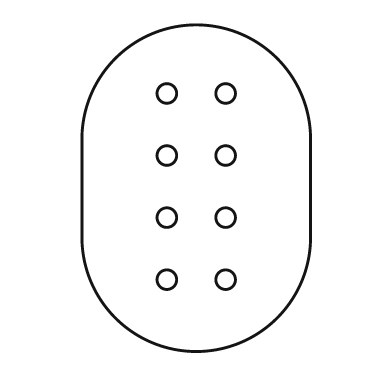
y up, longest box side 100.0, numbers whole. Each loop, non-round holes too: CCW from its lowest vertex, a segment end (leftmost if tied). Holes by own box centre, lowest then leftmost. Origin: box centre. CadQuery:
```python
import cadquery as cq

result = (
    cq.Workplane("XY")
    .moveTo(-35.0, -15.0)
    .threePointArc((0.0, -50.0), (35.0, -15.0))
    .lineTo(35.0, 15.0)
    .threePointArc((0.0, 50.0), (-35.0, 15.0))
    .close()
    .moveTo(-9.0, -28.0)
    .circle(3.0)
    .moveTo(9.0, -28.0)
    .circle(3.0)
    .moveTo(-9.0, -9.0)
    .circle(3.0)
    .moveTo(9.0, -9.0)
    .circle(3.0)
    .moveTo(-9.0, 10.0)
    .circle(3.0)
    .moveTo(9.0, 10.0)
    .circle(3.0)
    .moveTo(-9.0, 29.0)
    .circle(3.0)
    .moveTo(9.0, 29.0)
    .circle(3.0)
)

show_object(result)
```